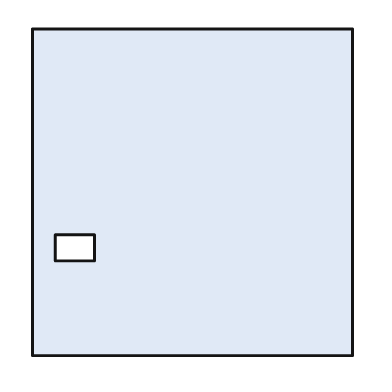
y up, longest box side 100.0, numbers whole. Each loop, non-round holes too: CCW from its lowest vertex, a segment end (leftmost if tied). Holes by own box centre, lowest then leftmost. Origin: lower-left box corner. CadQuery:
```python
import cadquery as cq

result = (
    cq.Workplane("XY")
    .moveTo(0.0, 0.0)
    .lineTo(98.0, 0.0)
    .lineTo(98.0, 100.0)
    .lineTo(0.0, 100.0)
    .close()
    .moveTo(7.0, 29.0)
    .lineTo(19.0, 29.0)
    .lineTo(19.0, 37.0)
    .lineTo(7.0, 37.0)
    .close()
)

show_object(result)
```